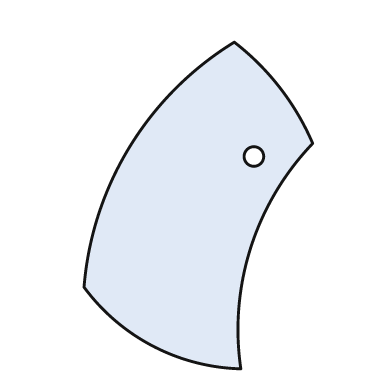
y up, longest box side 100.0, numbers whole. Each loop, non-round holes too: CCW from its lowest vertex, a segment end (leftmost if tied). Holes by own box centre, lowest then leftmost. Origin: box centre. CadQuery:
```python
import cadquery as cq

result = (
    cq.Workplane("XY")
    .moveTo(13.0, -50.0)
    .threePointArc((16.0, -13.0), (35.0, 19.0))
    .threePointArc((25.0, 36.0), (11.0, 50.0))
    .threePointArc((-21.0, 18.0), (-35.0, -25.0))
    .threePointArc((-14.0, -43.0), (13.0, -50.0))
    .close()
    .moveTo(17.0, 15.0)
    .circle(3.0)
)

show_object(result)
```